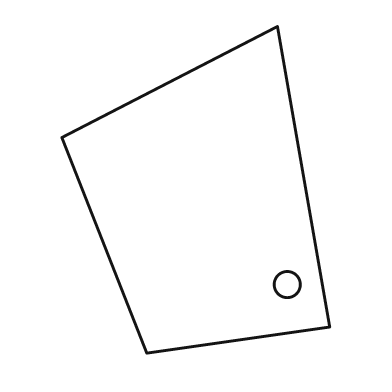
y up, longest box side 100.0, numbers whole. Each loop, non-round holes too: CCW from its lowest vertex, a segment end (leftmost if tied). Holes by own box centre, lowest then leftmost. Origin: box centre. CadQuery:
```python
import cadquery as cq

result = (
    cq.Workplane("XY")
    .moveTo(-15.0, -50.0)
    .lineTo(41.0, -42.0)
    .lineTo(25.0, 50.0)
    .lineTo(-41.0, 16.0)
    .close()
    .moveTo(28.0, -29.0)
    .circle(4.0)
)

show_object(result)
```